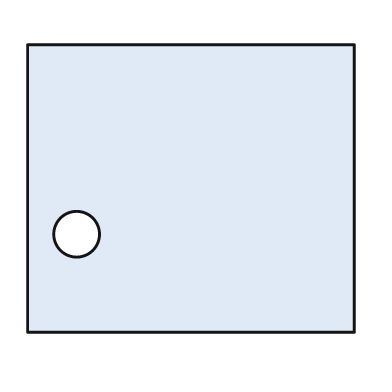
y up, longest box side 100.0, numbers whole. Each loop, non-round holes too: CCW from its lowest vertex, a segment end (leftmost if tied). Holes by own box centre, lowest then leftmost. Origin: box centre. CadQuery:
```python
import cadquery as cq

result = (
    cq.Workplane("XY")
    .moveTo(-50.0, -44.0)
    .lineTo(50.0, -44.0)
    .lineTo(50.0, 44.0)
    .lineTo(-50.0, 44.0)
    .close()
    .moveTo(-35.0, -14.0)
    .circle(7.0)
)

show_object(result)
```